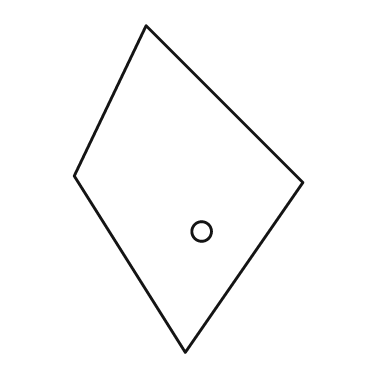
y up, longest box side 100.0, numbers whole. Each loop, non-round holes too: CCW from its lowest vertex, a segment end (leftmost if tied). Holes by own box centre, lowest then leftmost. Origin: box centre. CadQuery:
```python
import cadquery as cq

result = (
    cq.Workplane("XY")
    .moveTo(-1.0, -50.0)
    .lineTo(35.0, 2.0)
    .lineTo(-13.0, 50.0)
    .lineTo(-35.0, 4.0)
    .close()
    .moveTo(4.0, -13.0)
    .circle(3.0)
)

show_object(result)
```